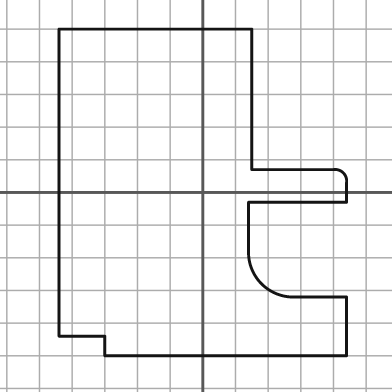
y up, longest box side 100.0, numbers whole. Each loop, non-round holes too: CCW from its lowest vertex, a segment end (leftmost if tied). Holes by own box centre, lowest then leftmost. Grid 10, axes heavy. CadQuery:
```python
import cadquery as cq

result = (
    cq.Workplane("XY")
    .moveTo(-30.0, -50.0)
    .lineTo(44.0, -50.0)
    .lineTo(44.0, -32.0)
    .lineTo(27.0, -32.0)
    .threePointArc((18.0, -28.0), (14.0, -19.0))
    .lineTo(14.0, -3.0)
    .lineTo(44.0, -3.0)
    .lineTo(44.0, 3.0)
    .threePointArc((43.0, 6.0), (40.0, 7.0))
    .lineTo(15.0, 7.0)
    .lineTo(15.0, 50.0)
    .lineTo(-44.0, 50.0)
    .lineTo(-44.0, -44.0)
    .lineTo(-30.0, -44.0)
    .close()
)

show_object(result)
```